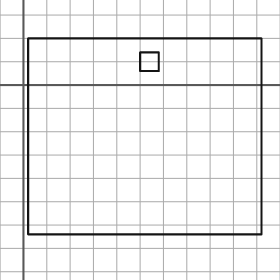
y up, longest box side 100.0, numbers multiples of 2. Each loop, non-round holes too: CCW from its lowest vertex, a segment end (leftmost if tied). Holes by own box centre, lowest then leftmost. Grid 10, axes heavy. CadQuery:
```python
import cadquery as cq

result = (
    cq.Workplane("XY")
    .moveTo(2.0, -64.0)
    .lineTo(102.0, -64.0)
    .lineTo(102.0, 20.0)
    .lineTo(2.0, 20.0)
    .close()
    .moveTo(50.0, 6.0)
    .lineTo(58.0, 6.0)
    .lineTo(58.0, 14.0)
    .lineTo(50.0, 14.0)
    .close()
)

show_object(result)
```